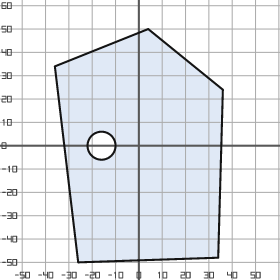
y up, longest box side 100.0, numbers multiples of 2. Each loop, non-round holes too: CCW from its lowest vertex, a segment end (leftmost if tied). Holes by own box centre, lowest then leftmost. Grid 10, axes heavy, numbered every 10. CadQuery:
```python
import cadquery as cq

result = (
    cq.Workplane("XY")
    .moveTo(-26.0, -50.0)
    .lineTo(34.0, -48.0)
    .lineTo(36.0, 24.0)
    .lineTo(4.0, 50.0)
    .lineTo(-36.0, 34.0)
    .close()
    .moveTo(-16.0, 0.0)
    .circle(6.0)
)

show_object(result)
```